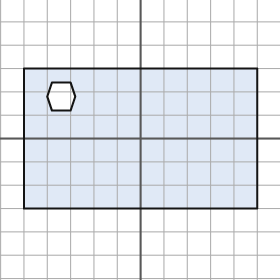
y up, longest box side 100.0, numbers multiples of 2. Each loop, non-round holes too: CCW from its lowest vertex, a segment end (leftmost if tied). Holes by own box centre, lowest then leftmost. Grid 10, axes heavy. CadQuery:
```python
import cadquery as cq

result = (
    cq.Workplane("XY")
    .moveTo(-50.0, -30.0)
    .lineTo(50.0, -30.0)
    .lineTo(50.0, 30.0)
    .lineTo(-50.0, 30.0)
    .close()
    .moveTo(-38.0, 12.0)
    .lineTo(-30.0, 12.0)
    .lineTo(-28.0, 18.0)
    .lineTo(-30.0, 24.0)
    .lineTo(-38.0, 24.0)
    .lineTo(-40.0, 18.0)
    .close()
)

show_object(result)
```